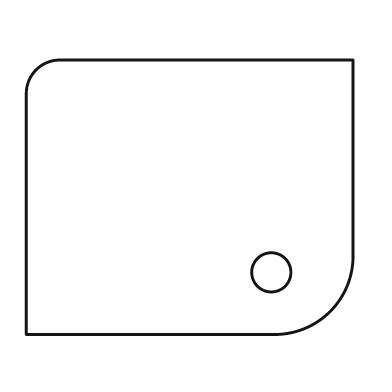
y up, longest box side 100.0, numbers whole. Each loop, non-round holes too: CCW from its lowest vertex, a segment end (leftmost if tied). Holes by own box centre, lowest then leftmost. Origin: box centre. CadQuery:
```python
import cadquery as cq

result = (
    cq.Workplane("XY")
    .moveTo(-50.0, -42.0)
    .lineTo(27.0, -42.0)
    .threePointArc((43.0, -35.0), (50.0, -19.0))
    .lineTo(50.0, 42.0)
    .lineTo(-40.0, 42.0)
    .threePointArc((-47.0, 39.0), (-50.0, 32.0))
    .close()
    .moveTo(25.0, -23.0)
    .circle(6.0)
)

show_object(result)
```